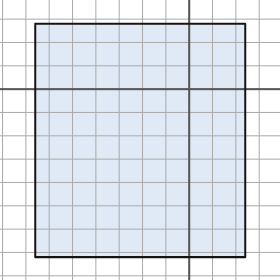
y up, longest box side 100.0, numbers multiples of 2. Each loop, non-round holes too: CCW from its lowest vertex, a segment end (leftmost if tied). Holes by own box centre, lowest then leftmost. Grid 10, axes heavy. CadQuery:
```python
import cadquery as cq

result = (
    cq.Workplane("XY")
    .moveTo(-66.0, -72.0)
    .lineTo(24.0, -72.0)
    .lineTo(24.0, 28.0)
    .lineTo(-66.0, 28.0)
    .close()
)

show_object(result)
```